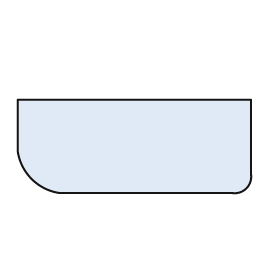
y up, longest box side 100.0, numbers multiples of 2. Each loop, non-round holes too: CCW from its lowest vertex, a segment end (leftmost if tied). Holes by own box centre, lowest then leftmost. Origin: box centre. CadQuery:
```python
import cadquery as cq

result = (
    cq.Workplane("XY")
    .moveTo(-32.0, -20.0)
    .lineTo(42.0, -20.0)
    .threePointArc((48.0, -18.0), (50.0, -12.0))
    .lineTo(50.0, 20.0)
    .lineTo(-50.0, 20.0)
    .lineTo(-50.0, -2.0)
    .threePointArc((-44.0, -14.0), (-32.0, -20.0))
    .close()
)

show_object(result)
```